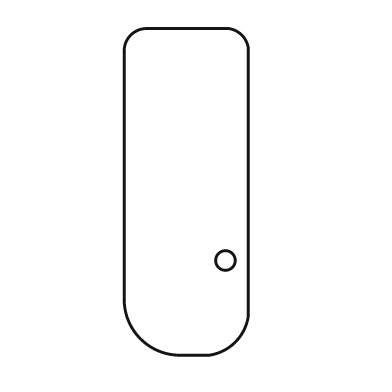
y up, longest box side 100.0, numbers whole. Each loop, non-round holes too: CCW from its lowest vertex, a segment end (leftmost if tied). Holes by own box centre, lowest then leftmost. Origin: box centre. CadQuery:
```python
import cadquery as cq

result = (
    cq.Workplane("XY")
    .moveTo(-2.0, -50.0)
    .lineTo(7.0, -50.0)
    .threePointArc((15.0, -46.0), (19.0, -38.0))
    .lineTo(19.0, 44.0)
    .threePointArc((17.0, 48.0), (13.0, 50.0))
    .lineTo(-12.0, 50.0)
    .threePointArc((-17.0, 48.0), (-19.0, 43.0))
    .lineTo(-19.0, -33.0)
    .threePointArc((-14.0, -45.0), (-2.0, -50.0))
    .close()
    .moveTo(12.0, -21.0)
    .circle(3.0)
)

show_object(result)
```